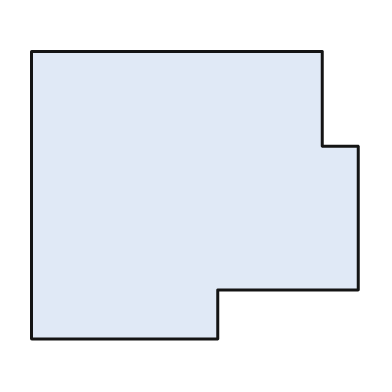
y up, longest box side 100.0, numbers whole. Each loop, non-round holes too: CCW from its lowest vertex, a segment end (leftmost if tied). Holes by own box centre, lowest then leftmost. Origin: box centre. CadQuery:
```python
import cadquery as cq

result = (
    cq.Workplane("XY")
    .moveTo(-50.0, -44.0)
    .lineTo(7.0, -44.0)
    .lineTo(7.0, -29.0)
    .lineTo(50.0, -29.0)
    .lineTo(50.0, 15.0)
    .lineTo(39.0, 15.0)
    .lineTo(39.0, 44.0)
    .lineTo(-50.0, 44.0)
    .close()
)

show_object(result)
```